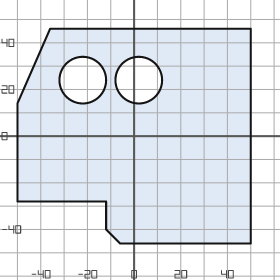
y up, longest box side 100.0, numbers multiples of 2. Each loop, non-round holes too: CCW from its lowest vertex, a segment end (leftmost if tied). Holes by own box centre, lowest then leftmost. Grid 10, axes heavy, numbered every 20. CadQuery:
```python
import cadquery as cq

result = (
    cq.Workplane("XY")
    .moveTo(-6.0, -46.0)
    .lineTo(50.0, -46.0)
    .lineTo(50.0, 46.0)
    .lineTo(-36.0, 46.0)
    .lineTo(-50.0, 14.0)
    .lineTo(-50.0, -28.0)
    .lineTo(-12.0, -28.0)
    .lineTo(-12.0, -40.0)
    .close()
    .moveTo(-22.0, 24.0)
    .circle(10.0)
    .moveTo(2.0, 24.0)
    .circle(10.0)
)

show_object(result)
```